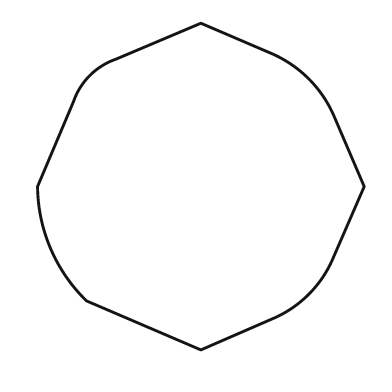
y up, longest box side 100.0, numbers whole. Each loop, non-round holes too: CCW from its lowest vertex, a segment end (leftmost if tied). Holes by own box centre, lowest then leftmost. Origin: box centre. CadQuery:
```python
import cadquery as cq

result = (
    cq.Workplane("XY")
    .moveTo(0.0, -50.0)
    .lineTo(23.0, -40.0)
    .threePointArc((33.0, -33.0), (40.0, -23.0))
    .lineTo(50.0, 0.0)
    .lineTo(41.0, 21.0)
    .threePointArc((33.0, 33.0), (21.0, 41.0))
    .lineTo(0.0, 50.0)
    .lineTo(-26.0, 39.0)
    .threePointArc((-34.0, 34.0), (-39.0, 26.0))
    .lineTo(-50.0, 0.0)
    .threePointArc((-46.0, -19.0), (-35.0, -35.0))
    .close()
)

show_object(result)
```